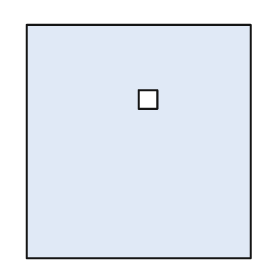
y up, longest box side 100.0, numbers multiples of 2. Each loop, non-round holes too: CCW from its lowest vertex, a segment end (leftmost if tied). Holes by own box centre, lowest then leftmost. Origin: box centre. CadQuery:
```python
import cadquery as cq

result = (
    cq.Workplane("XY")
    .moveTo(-48.0, -50.0)
    .lineTo(48.0, -50.0)
    .lineTo(48.0, 50.0)
    .lineTo(-48.0, 50.0)
    .close()
    .moveTo(0.0, 14.0)
    .lineTo(8.0, 14.0)
    .lineTo(8.0, 22.0)
    .lineTo(0.0, 22.0)
    .close()
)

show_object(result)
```